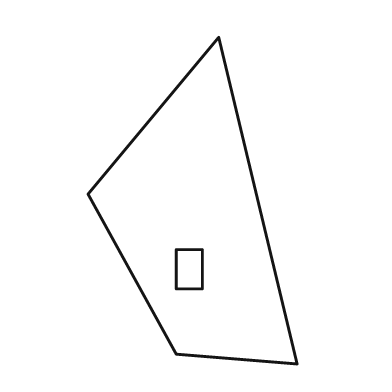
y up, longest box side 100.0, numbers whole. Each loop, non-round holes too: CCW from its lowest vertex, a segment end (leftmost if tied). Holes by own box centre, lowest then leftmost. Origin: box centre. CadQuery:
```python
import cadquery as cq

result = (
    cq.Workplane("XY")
    .moveTo(32.0, -50.0)
    .lineTo(8.0, 50.0)
    .lineTo(-32.0, 2.0)
    .lineTo(-5.0, -47.0)
    .close()
    .moveTo(-5.0, -27.0)
    .lineTo(3.0, -27.0)
    .lineTo(3.0, -15.0)
    .lineTo(-5.0, -15.0)
    .close()
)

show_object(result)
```